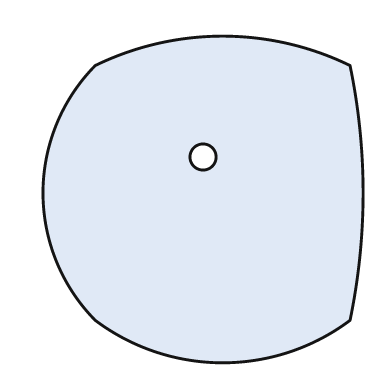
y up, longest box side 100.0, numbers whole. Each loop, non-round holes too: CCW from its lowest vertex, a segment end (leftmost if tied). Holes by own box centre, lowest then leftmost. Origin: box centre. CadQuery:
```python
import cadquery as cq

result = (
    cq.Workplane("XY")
    .moveTo(-33.0, -37.0)
    .threePointArc((6.0, -50.0), (45.0, -37.0))
    .threePointArc((49.0, 2.0), (45.0, 41.0))
    .threePointArc((6.0, 50.0), (-33.0, 41.0))
    .threePointArc((-49.0, 2.0), (-33.0, -37.0))
    .close()
    .moveTo(0.0, 13.0)
    .circle(4.0)
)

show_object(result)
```